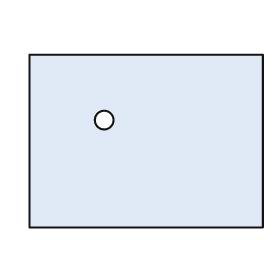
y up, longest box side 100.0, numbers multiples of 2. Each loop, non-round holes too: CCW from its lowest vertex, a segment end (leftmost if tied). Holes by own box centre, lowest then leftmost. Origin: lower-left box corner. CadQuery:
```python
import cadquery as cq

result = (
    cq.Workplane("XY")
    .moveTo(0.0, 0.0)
    .lineTo(100.0, 0.0)
    .lineTo(100.0, 74.0)
    .lineTo(0.0, 74.0)
    .close()
    .moveTo(32.0, 46.0)
    .circle(4.0)
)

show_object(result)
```